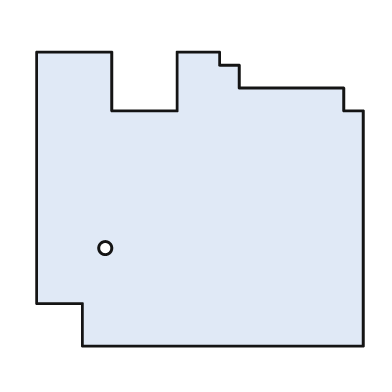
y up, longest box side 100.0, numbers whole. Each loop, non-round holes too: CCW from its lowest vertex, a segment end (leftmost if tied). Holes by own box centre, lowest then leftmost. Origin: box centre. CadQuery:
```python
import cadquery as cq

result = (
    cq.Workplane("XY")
    .moveTo(-36.0, -45.0)
    .lineTo(50.0, -45.0)
    .lineTo(50.0, 27.0)
    .lineTo(44.0, 27.0)
    .lineTo(44.0, 34.0)
    .lineTo(12.0, 34.0)
    .lineTo(12.0, 41.0)
    .lineTo(6.0, 41.0)
    .lineTo(6.0, 45.0)
    .lineTo(-7.0, 45.0)
    .lineTo(-7.0, 27.0)
    .lineTo(-27.0, 27.0)
    .lineTo(-27.0, 45.0)
    .lineTo(-50.0, 45.0)
    .lineTo(-50.0, -32.0)
    .lineTo(-36.0, -32.0)
    .close()
    .moveTo(-29.0, -15.0)
    .circle(2.0)
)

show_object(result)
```